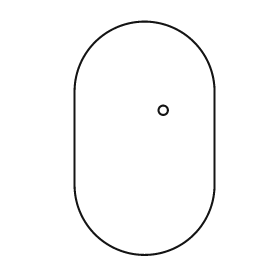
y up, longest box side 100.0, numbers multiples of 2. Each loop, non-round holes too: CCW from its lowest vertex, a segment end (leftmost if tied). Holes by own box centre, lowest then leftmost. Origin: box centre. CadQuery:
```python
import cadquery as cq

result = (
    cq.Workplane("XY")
    .moveTo(-30.0, -20.0)
    .threePointArc((0.0, -50.0), (30.0, -20.0))
    .lineTo(30.0, 20.0)
    .threePointArc((0.0, 50.0), (-30.0, 20.0))
    .close()
    .moveTo(8.0, 12.0)
    .circle(2.0)
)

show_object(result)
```